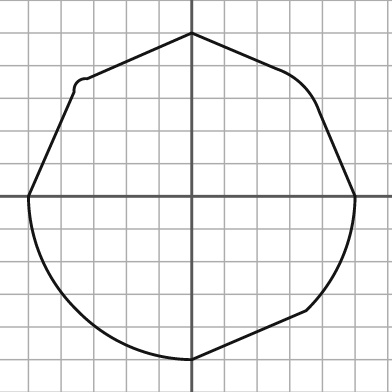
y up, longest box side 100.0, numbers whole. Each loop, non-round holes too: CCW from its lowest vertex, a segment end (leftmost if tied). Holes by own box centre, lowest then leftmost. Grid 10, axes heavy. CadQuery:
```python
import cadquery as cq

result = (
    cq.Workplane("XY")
    .moveTo(0.0, -50.0)
    .lineTo(35.0, -35.0)
    .threePointArc((46.0, -19.0), (50.0, 0.0))
    .lineTo(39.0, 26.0)
    .threePointArc((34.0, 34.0), (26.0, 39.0))
    .lineTo(0.0, 50.0)
    .lineTo(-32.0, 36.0)
    .threePointArc((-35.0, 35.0), (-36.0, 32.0))
    .lineTo(-50.0, 0.0)
    .threePointArc((-46.0, -19.0), (-35.0, -35.0))
    .threePointArc((-19.0, -46.0), (0.0, -50.0))
    .close()
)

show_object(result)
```